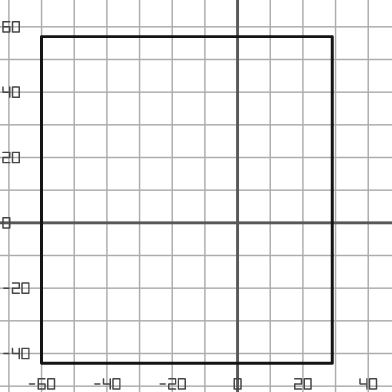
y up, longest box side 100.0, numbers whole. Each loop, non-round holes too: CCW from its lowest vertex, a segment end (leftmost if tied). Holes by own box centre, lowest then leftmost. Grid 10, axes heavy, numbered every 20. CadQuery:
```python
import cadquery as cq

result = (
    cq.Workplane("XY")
    .moveTo(-60.0, -43.0)
    .lineTo(29.0, -43.0)
    .lineTo(29.0, 57.0)
    .lineTo(-60.0, 57.0)
    .close()
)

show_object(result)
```